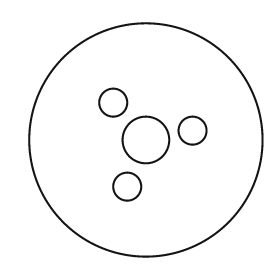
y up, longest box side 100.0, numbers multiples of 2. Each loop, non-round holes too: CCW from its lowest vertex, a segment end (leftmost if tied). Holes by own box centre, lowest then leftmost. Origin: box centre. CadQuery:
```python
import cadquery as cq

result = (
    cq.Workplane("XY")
    .moveTo(0.0, 0.0)
    .circle(50.0)
    .moveTo(-8.0, -20.0)
    .circle(6.0)
    .moveTo(0.0, 0.0)
    .circle(10.0)
    .moveTo(20.0, 4.0)
    .circle(6.0)
    .moveTo(-14.0, 16.0)
    .circle(6.0)
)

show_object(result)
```